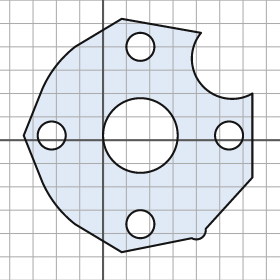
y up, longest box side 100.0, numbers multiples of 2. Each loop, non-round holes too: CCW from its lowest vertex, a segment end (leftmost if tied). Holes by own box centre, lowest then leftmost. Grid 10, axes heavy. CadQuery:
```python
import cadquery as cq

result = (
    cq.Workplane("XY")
    .moveTo(8.0, -48.0)
    .lineTo(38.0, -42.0)
    .threePointArc((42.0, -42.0), (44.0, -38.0))
    .lineTo(64.0, -16.0)
    .lineTo(64.0, 20.0)
    .threePointArc((42.0, 24.0), (42.0, 46.0))
    .lineTo(8.0, 52.0)
    .lineTo(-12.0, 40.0)
    .threePointArc((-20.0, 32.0), (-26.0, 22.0))
    .lineTo(-34.0, 2.0)
    .lineTo(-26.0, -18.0)
    .threePointArc((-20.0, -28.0), (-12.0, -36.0))
    .close()
    .moveTo(16.0, -36.0)
    .circle(6.0)
    .moveTo(-22.0, 2.0)
    .circle(6.0)
    .moveTo(16.0, 2.0)
    .circle(16.0)
    .moveTo(54.0, 2.0)
    .circle(6.0)
    .moveTo(16.0, 40.0)
    .circle(6.0)
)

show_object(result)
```